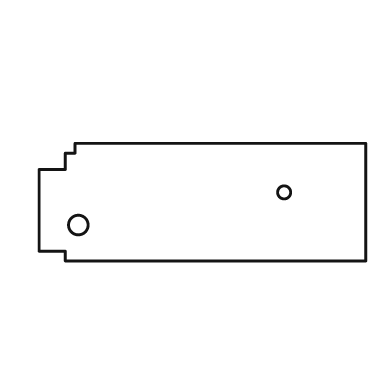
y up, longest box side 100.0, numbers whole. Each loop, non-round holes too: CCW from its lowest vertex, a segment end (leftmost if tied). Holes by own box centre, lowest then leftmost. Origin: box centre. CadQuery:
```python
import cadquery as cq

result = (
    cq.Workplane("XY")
    .moveTo(-42.0, -18.0)
    .lineTo(50.0, -18.0)
    .lineTo(50.0, 18.0)
    .lineTo(-39.0, 18.0)
    .lineTo(-39.0, 15.0)
    .lineTo(-42.0, 15.0)
    .lineTo(-42.0, 10.0)
    .lineTo(-50.0, 10.0)
    .lineTo(-50.0, -15.0)
    .lineTo(-42.0, -15.0)
    .close()
    .moveTo(-38.0, -7.0)
    .circle(3.0)
    .moveTo(25.0, 3.0)
    .circle(2.0)
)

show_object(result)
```